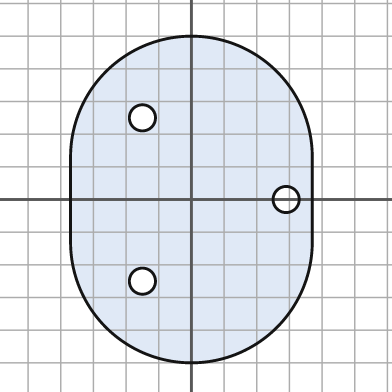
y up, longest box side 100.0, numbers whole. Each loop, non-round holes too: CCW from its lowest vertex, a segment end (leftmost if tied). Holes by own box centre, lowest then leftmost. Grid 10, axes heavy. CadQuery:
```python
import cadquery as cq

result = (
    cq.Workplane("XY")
    .moveTo(-37.0, -13.0)
    .threePointArc((0.0, -50.0), (37.0, -13.0))
    .lineTo(37.0, 13.0)
    .threePointArc((0.0, 50.0), (-37.0, 13.0))
    .close()
    .moveTo(-15.0, -25.0)
    .circle(4.0)
    .moveTo(29.0, 0.0)
    .circle(4.0)
    .moveTo(-15.0, 25.0)
    .circle(4.0)
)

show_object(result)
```